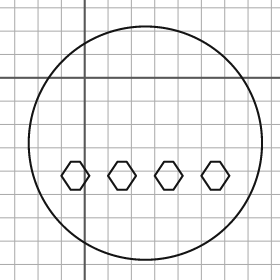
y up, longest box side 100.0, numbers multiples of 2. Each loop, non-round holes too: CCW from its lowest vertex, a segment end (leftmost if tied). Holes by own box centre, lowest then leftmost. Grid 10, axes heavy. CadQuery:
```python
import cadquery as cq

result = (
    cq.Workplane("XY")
    .moveTo(26.0, -28.0)
    .circle(50.0)
    .moveTo(-6.0, -48.0)
    .lineTo(-2.0, -48.0)
    .lineTo(2.0, -42.0)
    .lineTo(-2.0, -36.0)
    .lineTo(-6.0, -36.0)
    .lineTo(-10.0, -42.0)
    .close()
    .moveTo(14.0, -48.0)
    .lineTo(18.0, -48.0)
    .lineTo(22.0, -42.0)
    .lineTo(18.0, -36.0)
    .lineTo(14.0, -36.0)
    .lineTo(10.0, -42.0)
    .close()
    .moveTo(34.0, -48.0)
    .lineTo(38.0, -48.0)
    .lineTo(42.0, -42.0)
    .lineTo(38.0, -36.0)
    .lineTo(34.0, -36.0)
    .lineTo(30.0, -42.0)
    .close()
    .moveTo(54.0, -48.0)
    .lineTo(58.0, -48.0)
    .lineTo(62.0, -42.0)
    .lineTo(58.0, -36.0)
    .lineTo(54.0, -36.0)
    .lineTo(50.0, -42.0)
    .close()
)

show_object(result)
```